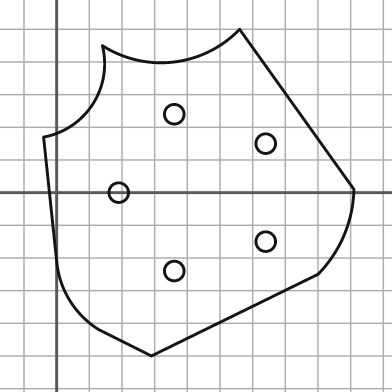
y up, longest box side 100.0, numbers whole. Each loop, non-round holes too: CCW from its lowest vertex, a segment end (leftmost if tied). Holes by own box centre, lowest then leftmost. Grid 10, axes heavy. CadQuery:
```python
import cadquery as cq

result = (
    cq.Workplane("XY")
    .moveTo(29.0, -50.0)
    .lineTo(80.0, -25.0)
    .threePointArc((88.0, -13.0), (91.0, 1.0))
    .lineTo(56.0, 50.0)
    .threePointArc((36.0, 40.0), (14.0, 45.0))
    .threePointArc((11.0, 27.0), (-4.0, 17.0))
    .lineTo(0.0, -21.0)
    .threePointArc((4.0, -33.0), (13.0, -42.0))
    .close()
    .moveTo(36.0, -24.0)
    .circle(3.0)
    .moveTo(64.0, -15.0)
    .circle(3.0)
    .moveTo(19.0, 0.0)
    .circle(3.0)
    .moveTo(64.0, 15.0)
    .circle(3.0)
    .moveTo(36.0, 24.0)
    .circle(3.0)
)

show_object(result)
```